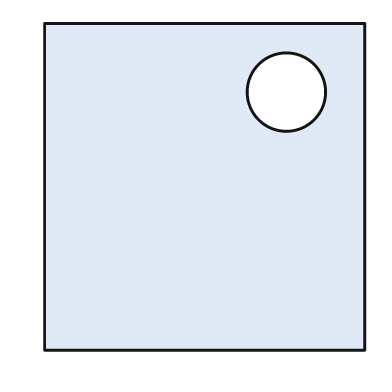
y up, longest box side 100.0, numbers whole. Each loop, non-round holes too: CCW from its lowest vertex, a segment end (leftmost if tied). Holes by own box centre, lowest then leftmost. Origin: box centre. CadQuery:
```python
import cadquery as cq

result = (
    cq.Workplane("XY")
    .moveTo(-49.0, -50.0)
    .lineTo(49.0, -50.0)
    .lineTo(49.0, 50.0)
    .lineTo(-49.0, 50.0)
    .close()
    .moveTo(25.0, 29.0)
    .circle(12.0)
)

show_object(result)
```